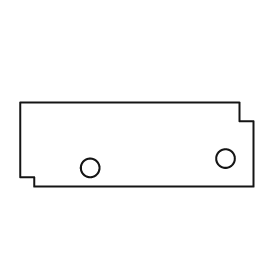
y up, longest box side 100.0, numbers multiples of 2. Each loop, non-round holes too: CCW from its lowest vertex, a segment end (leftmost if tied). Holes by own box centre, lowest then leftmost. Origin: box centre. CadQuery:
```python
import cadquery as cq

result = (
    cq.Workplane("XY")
    .moveTo(-44.0, -18.0)
    .lineTo(50.0, -18.0)
    .lineTo(50.0, 10.0)
    .lineTo(44.0, 10.0)
    .lineTo(44.0, 18.0)
    .lineTo(-50.0, 18.0)
    .lineTo(-50.0, -14.0)
    .lineTo(-44.0, -14.0)
    .close()
    .moveTo(-20.0, -10.0)
    .circle(4.0)
    .moveTo(38.0, -6.0)
    .circle(4.0)
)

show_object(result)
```